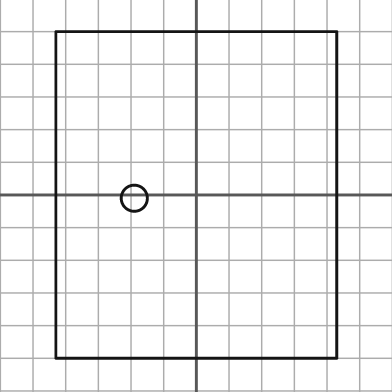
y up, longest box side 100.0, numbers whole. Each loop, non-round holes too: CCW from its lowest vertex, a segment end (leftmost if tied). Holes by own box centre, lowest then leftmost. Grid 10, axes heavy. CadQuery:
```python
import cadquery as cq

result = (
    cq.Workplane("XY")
    .moveTo(-43.0, -50.0)
    .lineTo(43.0, -50.0)
    .lineTo(43.0, 50.0)
    .lineTo(-43.0, 50.0)
    .close()
    .moveTo(-19.0, -1.0)
    .circle(4.0)
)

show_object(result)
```